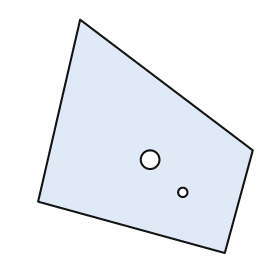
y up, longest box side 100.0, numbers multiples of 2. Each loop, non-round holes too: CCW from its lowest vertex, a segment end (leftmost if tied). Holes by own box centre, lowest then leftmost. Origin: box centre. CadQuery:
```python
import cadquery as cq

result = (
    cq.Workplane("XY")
    .moveTo(34.0, -50.0)
    .lineTo(46.0, -6.0)
    .lineTo(-28.0, 50.0)
    .lineTo(-46.0, -28.0)
    .close()
    .moveTo(16.0, -24.0)
    .circle(2.0)
    .moveTo(2.0, -10.0)
    .circle(4.0)
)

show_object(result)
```